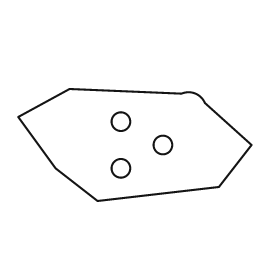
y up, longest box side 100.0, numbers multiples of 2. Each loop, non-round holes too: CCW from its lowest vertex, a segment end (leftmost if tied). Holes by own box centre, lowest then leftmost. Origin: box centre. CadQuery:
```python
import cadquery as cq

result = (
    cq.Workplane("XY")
    .moveTo(-16.0, -24.0)
    .lineTo(36.0, -18.0)
    .lineTo(50.0, 0.0)
    .lineTo(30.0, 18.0)
    .threePointArc((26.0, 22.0), (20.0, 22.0))
    .lineTo(-28.0, 24.0)
    .lineTo(-50.0, 12.0)
    .lineTo(-34.0, -10.0)
    .close()
    .moveTo(-6.0, -10.0)
    .circle(4.0)
    .moveTo(12.0, 0.0)
    .circle(4.0)
    .moveTo(-6.0, 10.0)
    .circle(4.0)
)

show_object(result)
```